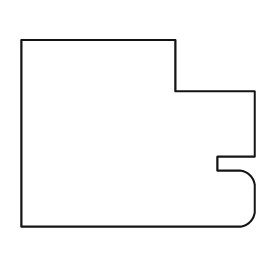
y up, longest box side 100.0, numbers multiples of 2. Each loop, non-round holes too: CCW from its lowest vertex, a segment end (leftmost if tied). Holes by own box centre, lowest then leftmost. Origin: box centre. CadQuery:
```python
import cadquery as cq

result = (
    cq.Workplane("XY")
    .moveTo(-50.0, -40.0)
    .lineTo(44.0, -40.0)
    .threePointArc((48.0, -38.0), (50.0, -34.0))
    .lineTo(50.0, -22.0)
    .threePointArc((48.0, -18.0), (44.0, -16.0))
    .lineTo(34.0, -16.0)
    .lineTo(34.0, -10.0)
    .lineTo(50.0, -10.0)
    .lineTo(50.0, 18.0)
    .lineTo(16.0, 18.0)
    .lineTo(16.0, 40.0)
    .lineTo(-50.0, 40.0)
    .close()
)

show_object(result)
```